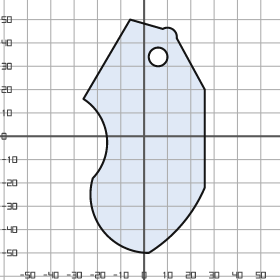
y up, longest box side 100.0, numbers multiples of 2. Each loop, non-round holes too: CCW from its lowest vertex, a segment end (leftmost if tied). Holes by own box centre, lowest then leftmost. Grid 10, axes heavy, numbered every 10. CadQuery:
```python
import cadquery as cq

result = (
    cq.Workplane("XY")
    .moveTo(2.0, -50.0)
    .threePointArc((16.0, -38.0), (26.0, -22.0))
    .lineTo(26.0, 20.0)
    .lineTo(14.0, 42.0)
    .threePointArc((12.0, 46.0), (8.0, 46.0))
    .lineTo(-6.0, 50.0)
    .lineTo(-26.0, 16.0)
    .threePointArc((-16.0, 0.0), (-22.0, -18.0))
    .threePointArc((-18.0, -40.0), (2.0, -50.0))
    .close()
    .moveTo(6.0, 34.0)
    .circle(4.0)
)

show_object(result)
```